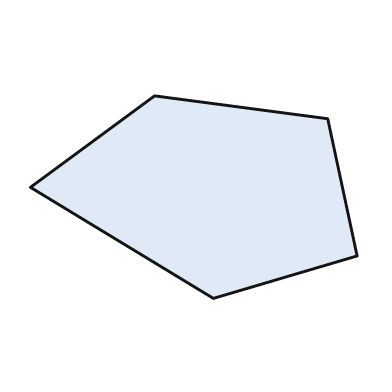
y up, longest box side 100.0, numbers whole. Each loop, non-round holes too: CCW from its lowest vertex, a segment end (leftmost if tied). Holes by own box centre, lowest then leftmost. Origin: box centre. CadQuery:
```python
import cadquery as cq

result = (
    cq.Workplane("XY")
    .moveTo(6.0, -31.0)
    .lineTo(50.0, -18.0)
    .lineTo(41.0, 24.0)
    .lineTo(-12.0, 31.0)
    .lineTo(-50.0, 3.0)
    .close()
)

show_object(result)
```